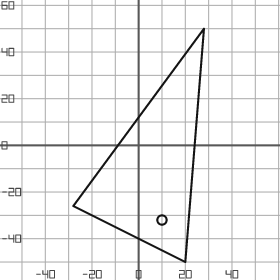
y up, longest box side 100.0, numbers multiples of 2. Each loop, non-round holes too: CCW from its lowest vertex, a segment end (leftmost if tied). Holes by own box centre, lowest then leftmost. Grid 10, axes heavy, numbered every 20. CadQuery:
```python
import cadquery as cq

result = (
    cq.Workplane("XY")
    .moveTo(20.0, -50.0)
    .lineTo(28.0, 50.0)
    .lineTo(-28.0, -26.0)
    .close()
    .moveTo(10.0, -32.0)
    .circle(2.0)
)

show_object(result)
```